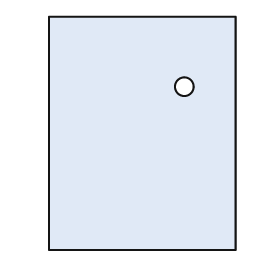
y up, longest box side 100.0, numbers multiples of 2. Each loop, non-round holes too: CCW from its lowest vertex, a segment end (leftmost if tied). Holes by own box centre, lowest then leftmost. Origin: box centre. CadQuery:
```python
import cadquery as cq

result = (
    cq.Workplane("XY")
    .moveTo(-40.0, -50.0)
    .lineTo(40.0, -50.0)
    .lineTo(40.0, 50.0)
    .lineTo(-40.0, 50.0)
    .close()
    .moveTo(18.0, 20.0)
    .circle(4.0)
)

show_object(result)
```